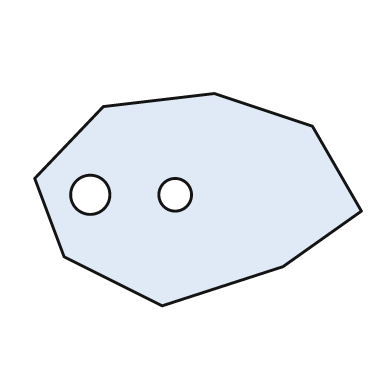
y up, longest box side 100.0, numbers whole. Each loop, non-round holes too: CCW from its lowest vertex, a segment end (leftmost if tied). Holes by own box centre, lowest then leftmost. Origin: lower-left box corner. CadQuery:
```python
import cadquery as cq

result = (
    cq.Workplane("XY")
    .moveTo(39.0, 0.0)
    .lineTo(76.0, 12.0)
    .lineTo(100.0, 29.0)
    .lineTo(85.0, 55.0)
    .lineTo(55.0, 65.0)
    .lineTo(21.0, 61.0)
    .lineTo(0.0, 39.0)
    .lineTo(9.0, 15.0)
    .close()
    .moveTo(17.0, 34.0)
    .circle(6.0)
    .moveTo(43.0, 34.0)
    .circle(5.0)
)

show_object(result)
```